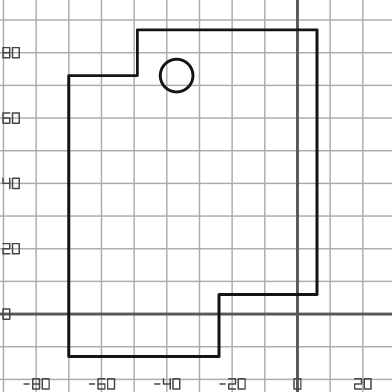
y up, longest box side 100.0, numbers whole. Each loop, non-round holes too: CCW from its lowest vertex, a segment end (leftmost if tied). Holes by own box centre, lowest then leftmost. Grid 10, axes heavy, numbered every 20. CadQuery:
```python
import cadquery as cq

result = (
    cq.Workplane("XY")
    .moveTo(-70.0, -13.0)
    .lineTo(-24.0, -13.0)
    .lineTo(-24.0, 6.0)
    .lineTo(6.0, 6.0)
    .lineTo(6.0, 87.0)
    .lineTo(-49.0, 87.0)
    .lineTo(-49.0, 73.0)
    .lineTo(-70.0, 73.0)
    .close()
    .moveTo(-37.0, 73.0)
    .circle(5.0)
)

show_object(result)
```